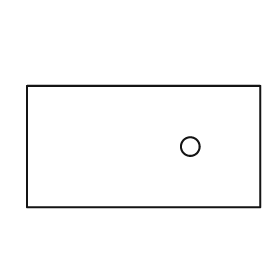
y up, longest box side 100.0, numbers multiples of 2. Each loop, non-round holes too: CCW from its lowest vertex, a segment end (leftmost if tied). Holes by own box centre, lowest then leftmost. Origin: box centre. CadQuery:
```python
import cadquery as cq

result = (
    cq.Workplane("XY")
    .moveTo(-50.0, -26.0)
    .lineTo(50.0, -26.0)
    .lineTo(50.0, 26.0)
    .lineTo(-50.0, 26.0)
    .close()
    .moveTo(20.0, 0.0)
    .circle(4.0)
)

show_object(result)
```